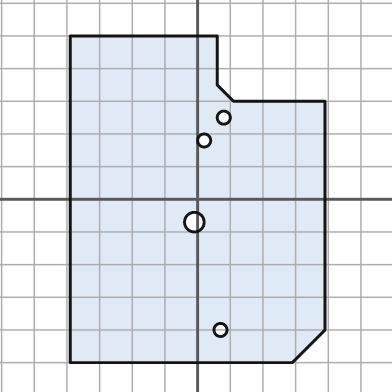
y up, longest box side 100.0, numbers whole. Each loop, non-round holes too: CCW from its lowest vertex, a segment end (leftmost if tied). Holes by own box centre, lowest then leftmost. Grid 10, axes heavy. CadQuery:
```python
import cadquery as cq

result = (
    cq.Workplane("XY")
    .moveTo(-39.0, -50.0)
    .lineTo(29.0, -50.0)
    .lineTo(39.0, -40.0)
    .lineTo(39.0, 30.0)
    .lineTo(11.0, 30.0)
    .lineTo(6.0, 35.0)
    .lineTo(6.0, 50.0)
    .lineTo(-39.0, 50.0)
    .close()
    .moveTo(7.0, -40.0)
    .circle(2.0)
    .moveTo(-1.0, -7.0)
    .circle(3.0)
    .moveTo(2.0, 18.0)
    .circle(2.0)
    .moveTo(8.0, 25.0)
    .circle(2.0)
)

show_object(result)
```